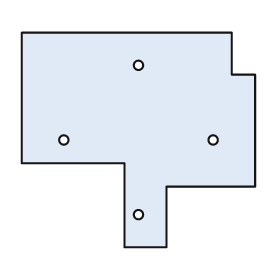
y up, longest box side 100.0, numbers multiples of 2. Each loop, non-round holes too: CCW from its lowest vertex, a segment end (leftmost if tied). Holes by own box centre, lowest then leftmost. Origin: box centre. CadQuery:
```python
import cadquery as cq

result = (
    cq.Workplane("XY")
    .moveTo(-6.0, -46.0)
    .lineTo(12.0, -46.0)
    .lineTo(12.0, -20.0)
    .lineTo(50.0, -20.0)
    .lineTo(50.0, 28.0)
    .lineTo(40.0, 28.0)
    .lineTo(40.0, 46.0)
    .lineTo(-50.0, 46.0)
    .lineTo(-50.0, -10.0)
    .lineTo(-6.0, -10.0)
    .close()
    .moveTo(0.0, -32.0)
    .circle(2.0)
    .moveTo(-32.0, 0.0)
    .circle(2.0)
    .moveTo(32.0, 0.0)
    .circle(2.0)
    .moveTo(0.0, 32.0)
    .circle(2.0)
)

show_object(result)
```